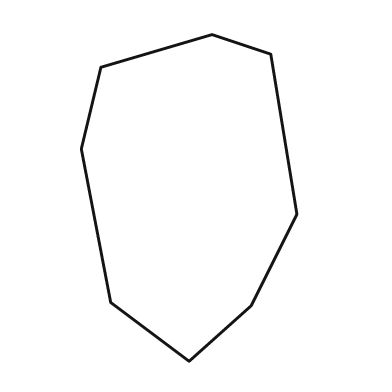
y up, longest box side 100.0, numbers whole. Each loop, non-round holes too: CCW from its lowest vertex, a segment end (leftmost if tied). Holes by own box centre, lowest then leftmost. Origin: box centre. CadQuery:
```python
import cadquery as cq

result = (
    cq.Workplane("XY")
    .moveTo(0.0, -50.0)
    .lineTo(19.0, -33.0)
    .lineTo(33.0, -5.0)
    .lineTo(25.0, 44.0)
    .lineTo(7.0, 50.0)
    .lineTo(-27.0, 40.0)
    .lineTo(-33.0, 15.0)
    .lineTo(-24.0, -32.0)
    .close()
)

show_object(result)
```